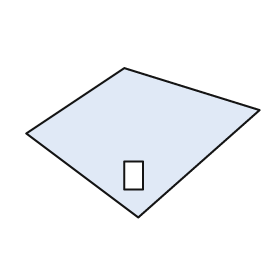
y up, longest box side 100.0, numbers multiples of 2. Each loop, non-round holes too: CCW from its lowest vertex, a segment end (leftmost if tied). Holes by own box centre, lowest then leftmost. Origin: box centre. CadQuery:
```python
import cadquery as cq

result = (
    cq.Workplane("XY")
    .moveTo(-2.0, -32.0)
    .lineTo(50.0, 14.0)
    .lineTo(-8.0, 32.0)
    .lineTo(-50.0, 4.0)
    .close()
    .moveTo(-8.0, -20.0)
    .lineTo(0.0, -20.0)
    .lineTo(0.0, -8.0)
    .lineTo(-8.0, -8.0)
    .close()
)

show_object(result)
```